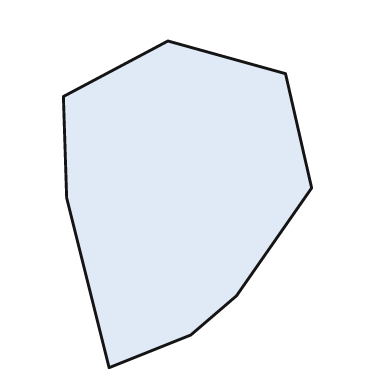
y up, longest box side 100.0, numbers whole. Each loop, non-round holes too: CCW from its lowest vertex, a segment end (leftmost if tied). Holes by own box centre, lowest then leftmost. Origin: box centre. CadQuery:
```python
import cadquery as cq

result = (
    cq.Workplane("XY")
    .moveTo(-24.0, -50.0)
    .lineTo(1.0, -40.0)
    .lineTo(15.0, -28.0)
    .lineTo(38.0, 5.0)
    .lineTo(30.0, 40.0)
    .lineTo(-6.0, 50.0)
    .lineTo(-38.0, 33.0)
    .lineTo(-37.0, 2.0)
    .close()
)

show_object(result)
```